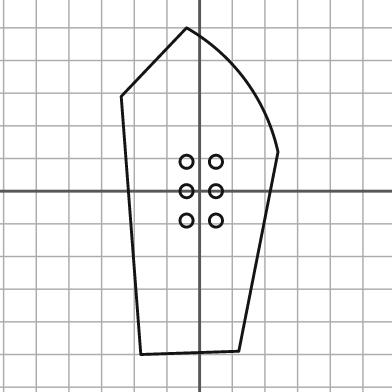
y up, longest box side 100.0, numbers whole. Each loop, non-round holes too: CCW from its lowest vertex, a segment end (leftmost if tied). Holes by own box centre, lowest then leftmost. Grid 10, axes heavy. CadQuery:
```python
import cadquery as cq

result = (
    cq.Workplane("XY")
    .moveTo(-18.0, -50.0)
    .lineTo(12.0, -49.0)
    .lineTo(24.0, 12.0)
    .threePointArc((14.0, 34.0), (-4.0, 50.0))
    .lineTo(-24.0, 29.0)
    .close()
    .moveTo(-4.0, -9.0)
    .circle(2.0)
    .moveTo(5.0, -9.0)
    .circle(2.0)
    .moveTo(-4.0, 0.0)
    .circle(2.0)
    .moveTo(5.0, 0.0)
    .circle(2.0)
    .moveTo(-4.0, 9.0)
    .circle(2.0)
    .moveTo(5.0, 9.0)
    .circle(2.0)
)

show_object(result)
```